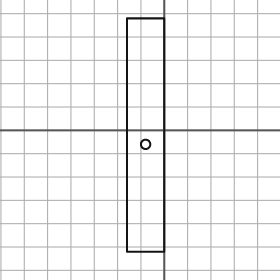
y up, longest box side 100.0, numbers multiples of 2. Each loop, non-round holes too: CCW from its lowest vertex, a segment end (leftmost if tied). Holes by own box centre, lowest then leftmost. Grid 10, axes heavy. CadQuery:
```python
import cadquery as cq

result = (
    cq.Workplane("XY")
    .moveTo(-16.0, -52.0)
    .lineTo(0.0, -52.0)
    .lineTo(0.0, 48.0)
    .lineTo(-16.0, 48.0)
    .close()
    .moveTo(-8.0, -6.0)
    .circle(2.0)
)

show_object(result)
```